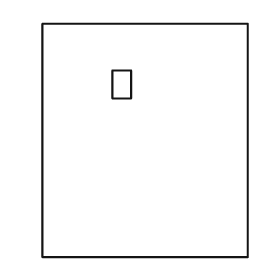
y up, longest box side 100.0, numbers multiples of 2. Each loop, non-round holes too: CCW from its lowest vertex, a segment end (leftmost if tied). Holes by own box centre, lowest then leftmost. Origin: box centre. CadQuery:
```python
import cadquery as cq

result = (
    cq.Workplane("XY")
    .moveTo(-44.0, -50.0)
    .lineTo(44.0, -50.0)
    .lineTo(44.0, 50.0)
    .lineTo(-44.0, 50.0)
    .close()
    .moveTo(-14.0, 18.0)
    .lineTo(-6.0, 18.0)
    .lineTo(-6.0, 30.0)
    .lineTo(-14.0, 30.0)
    .close()
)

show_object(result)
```